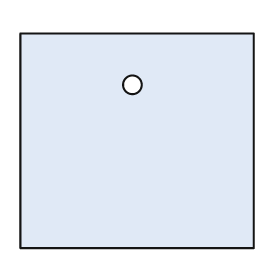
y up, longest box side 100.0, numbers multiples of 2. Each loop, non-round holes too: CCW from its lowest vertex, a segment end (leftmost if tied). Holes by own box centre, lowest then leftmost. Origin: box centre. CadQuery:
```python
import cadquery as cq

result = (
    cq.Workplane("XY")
    .moveTo(-50.0, -46.0)
    .lineTo(50.0, -46.0)
    .lineTo(50.0, 46.0)
    .lineTo(-50.0, 46.0)
    .close()
    .moveTo(-2.0, 24.0)
    .circle(4.0)
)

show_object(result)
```